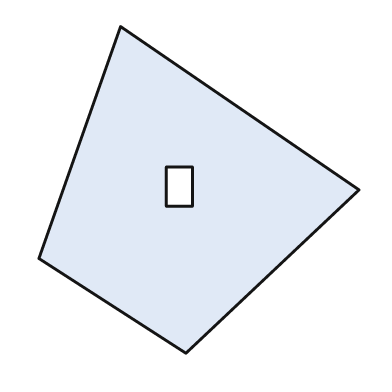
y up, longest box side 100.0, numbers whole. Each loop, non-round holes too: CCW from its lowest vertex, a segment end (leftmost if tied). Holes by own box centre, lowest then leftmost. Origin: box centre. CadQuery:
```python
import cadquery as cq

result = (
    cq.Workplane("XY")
    .moveTo(-4.0, -50.0)
    .lineTo(49.0, 0.0)
    .lineTo(-24.0, 50.0)
    .lineTo(-49.0, -21.0)
    .close()
    .moveTo(-10.0, -5.0)
    .lineTo(-2.0, -5.0)
    .lineTo(-2.0, 7.0)
    .lineTo(-10.0, 7.0)
    .close()
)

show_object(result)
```